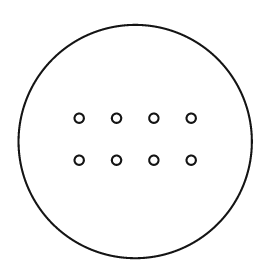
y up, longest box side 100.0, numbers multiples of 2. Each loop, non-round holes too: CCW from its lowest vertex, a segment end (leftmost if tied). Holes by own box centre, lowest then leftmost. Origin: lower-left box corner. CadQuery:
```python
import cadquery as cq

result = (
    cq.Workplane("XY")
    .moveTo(50.0, 50.0)
    .circle(50.0)
    .moveTo(26.0, 42.0)
    .circle(2.0)
    .moveTo(42.0, 42.0)
    .circle(2.0)
    .moveTo(58.0, 42.0)
    .circle(2.0)
    .moveTo(74.0, 42.0)
    .circle(2.0)
    .moveTo(26.0, 60.0)
    .circle(2.0)
    .moveTo(42.0, 60.0)
    .circle(2.0)
    .moveTo(58.0, 60.0)
    .circle(2.0)
    .moveTo(74.0, 60.0)
    .circle(2.0)
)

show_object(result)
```